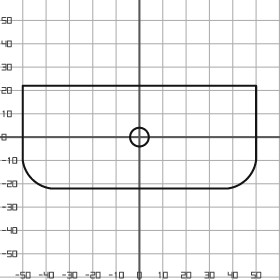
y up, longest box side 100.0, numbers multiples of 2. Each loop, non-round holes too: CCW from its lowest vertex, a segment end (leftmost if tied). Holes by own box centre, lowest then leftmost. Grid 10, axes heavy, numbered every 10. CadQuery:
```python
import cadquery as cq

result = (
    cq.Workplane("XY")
    .moveTo(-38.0, -22.0)
    .lineTo(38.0, -22.0)
    .threePointArc((46.0, -18.0), (50.0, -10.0))
    .lineTo(50.0, 22.0)
    .lineTo(-50.0, 22.0)
    .lineTo(-50.0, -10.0)
    .threePointArc((-46.0, -18.0), (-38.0, -22.0))
    .close()
    .moveTo(0.0, 0.0)
    .circle(4.0)
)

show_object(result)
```